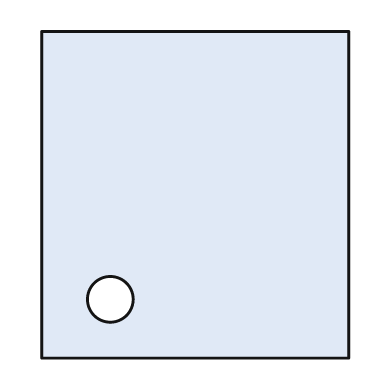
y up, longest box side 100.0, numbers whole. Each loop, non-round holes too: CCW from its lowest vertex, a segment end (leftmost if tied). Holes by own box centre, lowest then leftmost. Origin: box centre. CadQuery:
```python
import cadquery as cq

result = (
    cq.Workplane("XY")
    .moveTo(-47.0, -50.0)
    .lineTo(47.0, -50.0)
    .lineTo(47.0, 50.0)
    .lineTo(-47.0, 50.0)
    .close()
    .moveTo(-26.0, -32.0)
    .circle(7.0)
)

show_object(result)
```